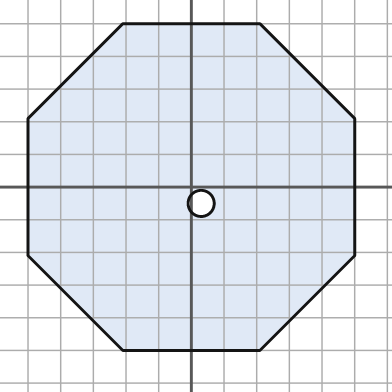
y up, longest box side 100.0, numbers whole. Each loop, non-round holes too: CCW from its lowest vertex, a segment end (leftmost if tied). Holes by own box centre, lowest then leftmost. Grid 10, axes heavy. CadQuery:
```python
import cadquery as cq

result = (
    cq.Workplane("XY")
    .moveTo(-21.0, -50.0)
    .lineTo(21.0, -50.0)
    .lineTo(50.0, -21.0)
    .lineTo(50.0, 21.0)
    .lineTo(21.0, 50.0)
    .lineTo(-21.0, 50.0)
    .lineTo(-50.0, 21.0)
    .lineTo(-50.0, -21.0)
    .close()
    .moveTo(3.0, -5.0)
    .circle(4.0)
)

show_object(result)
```